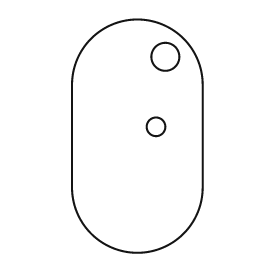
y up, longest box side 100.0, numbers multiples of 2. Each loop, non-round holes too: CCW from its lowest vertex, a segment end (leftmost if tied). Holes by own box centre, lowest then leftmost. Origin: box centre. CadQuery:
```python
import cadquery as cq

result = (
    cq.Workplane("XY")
    .moveTo(-28.0, -22.0)
    .threePointArc((0.0, -50.0), (28.0, -22.0))
    .lineTo(28.0, 22.0)
    .threePointArc((0.0, 50.0), (-28.0, 22.0))
    .close()
    .moveTo(8.0, 4.0)
    .circle(4.0)
    .moveTo(12.0, 34.0)
    .circle(6.0)
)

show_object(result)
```